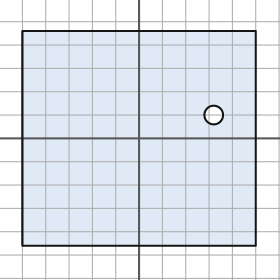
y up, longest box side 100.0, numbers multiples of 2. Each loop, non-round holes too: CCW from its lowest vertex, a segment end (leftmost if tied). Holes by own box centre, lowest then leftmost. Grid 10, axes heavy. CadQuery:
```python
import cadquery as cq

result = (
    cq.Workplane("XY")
    .moveTo(-50.0, -46.0)
    .lineTo(50.0, -46.0)
    .lineTo(50.0, 46.0)
    .lineTo(-50.0, 46.0)
    .close()
    .moveTo(32.0, 10.0)
    .circle(4.0)
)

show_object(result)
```